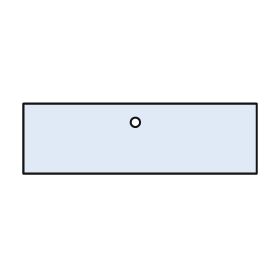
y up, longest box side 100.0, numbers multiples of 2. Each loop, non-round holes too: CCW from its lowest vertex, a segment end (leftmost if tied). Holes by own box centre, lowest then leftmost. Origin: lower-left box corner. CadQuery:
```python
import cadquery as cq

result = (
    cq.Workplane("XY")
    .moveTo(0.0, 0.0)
    .lineTo(100.0, 0.0)
    .lineTo(100.0, 30.0)
    .lineTo(0.0, 30.0)
    .close()
    .moveTo(48.0, 22.0)
    .circle(2.0)
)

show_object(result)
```